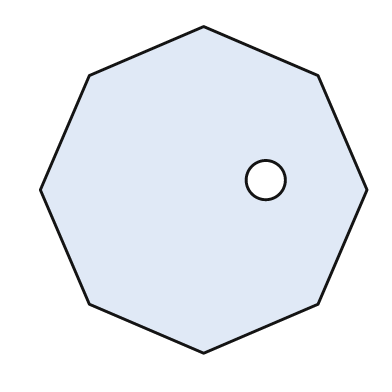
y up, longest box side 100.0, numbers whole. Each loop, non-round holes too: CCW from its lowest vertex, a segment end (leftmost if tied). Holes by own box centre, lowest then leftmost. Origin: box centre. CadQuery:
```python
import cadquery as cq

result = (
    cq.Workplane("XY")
    .moveTo(0.0, -50.0)
    .lineTo(35.0, -35.0)
    .lineTo(50.0, 0.0)
    .lineTo(35.0, 35.0)
    .lineTo(0.0, 50.0)
    .lineTo(-35.0, 35.0)
    .lineTo(-50.0, 0.0)
    .lineTo(-35.0, -35.0)
    .close()
    .moveTo(19.0, 3.0)
    .circle(6.0)
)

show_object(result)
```